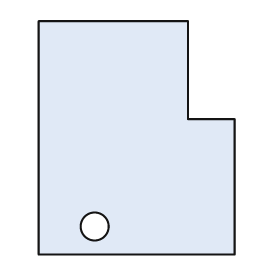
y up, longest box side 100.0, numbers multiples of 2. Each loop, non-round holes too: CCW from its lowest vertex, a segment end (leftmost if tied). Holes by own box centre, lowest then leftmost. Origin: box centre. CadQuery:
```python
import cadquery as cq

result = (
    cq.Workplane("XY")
    .moveTo(-42.0, -50.0)
    .lineTo(42.0, -50.0)
    .lineTo(42.0, 8.0)
    .lineTo(22.0, 8.0)
    .lineTo(22.0, 50.0)
    .lineTo(-42.0, 50.0)
    .close()
    .moveTo(-18.0, -38.0)
    .circle(6.0)
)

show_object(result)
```